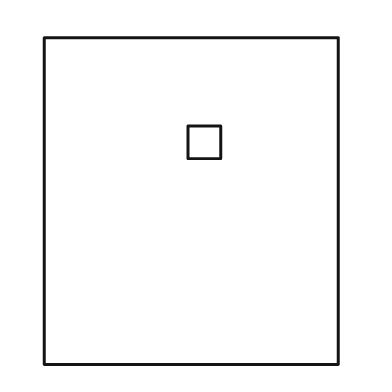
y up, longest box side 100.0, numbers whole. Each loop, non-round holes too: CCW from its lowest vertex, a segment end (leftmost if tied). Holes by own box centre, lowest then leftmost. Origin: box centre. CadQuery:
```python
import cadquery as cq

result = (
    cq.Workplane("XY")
    .moveTo(-45.0, -50.0)
    .lineTo(45.0, -50.0)
    .lineTo(45.0, 50.0)
    .lineTo(-45.0, 50.0)
    .close()
    .moveTo(-1.0, 13.0)
    .lineTo(9.0, 13.0)
    .lineTo(9.0, 23.0)
    .lineTo(-1.0, 23.0)
    .close()
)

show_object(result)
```